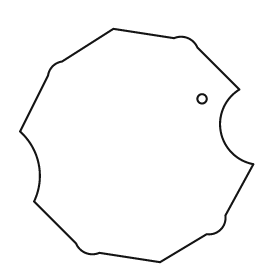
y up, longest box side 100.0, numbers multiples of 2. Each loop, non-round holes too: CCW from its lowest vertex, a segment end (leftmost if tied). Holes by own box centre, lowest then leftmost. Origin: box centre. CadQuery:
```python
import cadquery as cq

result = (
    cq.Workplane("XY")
    .moveTo(10.0, -50.0)
    .lineTo(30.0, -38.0)
    .threePointArc((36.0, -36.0), (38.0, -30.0))
    .lineTo(50.0, -8.0)
    .threePointArc((36.0, 6.0), (44.0, 24.0))
    .lineTo(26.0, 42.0)
    .threePointArc((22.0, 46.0), (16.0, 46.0))
    .lineTo(-10.0, 50.0)
    .lineTo(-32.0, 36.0)
    .threePointArc((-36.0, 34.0), (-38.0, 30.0))
    .lineTo(-50.0, 6.0)
    .threePointArc((-42.0, -8.0), (-44.0, -24.0))
    .lineTo(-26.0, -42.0)
    .threePointArc((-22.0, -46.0), (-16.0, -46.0))
    .close()
    .moveTo(28.0, 20.0)
    .circle(2.0)
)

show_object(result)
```